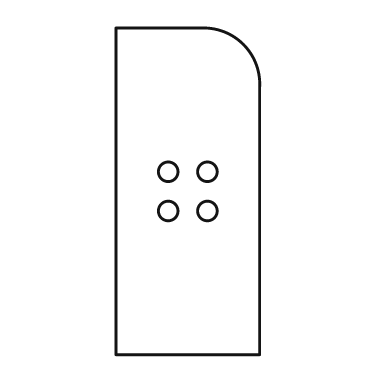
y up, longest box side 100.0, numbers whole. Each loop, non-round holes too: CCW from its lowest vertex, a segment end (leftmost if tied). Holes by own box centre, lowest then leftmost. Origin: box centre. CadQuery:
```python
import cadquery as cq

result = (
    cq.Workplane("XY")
    .moveTo(-22.0, -50.0)
    .lineTo(22.0, -50.0)
    .lineTo(22.0, 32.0)
    .threePointArc((17.0, 45.0), (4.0, 50.0))
    .lineTo(-22.0, 50.0)
    .close()
    .moveTo(-6.0, -6.0)
    .circle(3.0)
    .moveTo(6.0, -6.0)
    .circle(3.0)
    .moveTo(-6.0, 6.0)
    .circle(3.0)
    .moveTo(6.0, 6.0)
    .circle(3.0)
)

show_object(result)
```